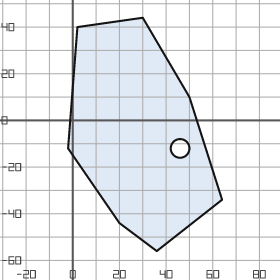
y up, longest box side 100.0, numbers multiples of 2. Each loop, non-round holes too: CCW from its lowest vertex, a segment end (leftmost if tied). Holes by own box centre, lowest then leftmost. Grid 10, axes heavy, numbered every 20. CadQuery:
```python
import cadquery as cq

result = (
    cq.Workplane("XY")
    .moveTo(36.0, -56.0)
    .lineTo(64.0, -34.0)
    .lineTo(50.0, 10.0)
    .lineTo(30.0, 44.0)
    .lineTo(2.0, 40.0)
    .lineTo(-2.0, -12.0)
    .lineTo(20.0, -44.0)
    .close()
    .moveTo(46.0, -12.0)
    .circle(4.0)
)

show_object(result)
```